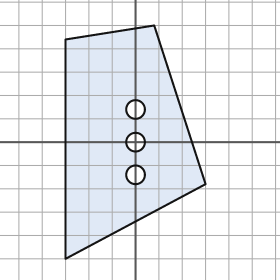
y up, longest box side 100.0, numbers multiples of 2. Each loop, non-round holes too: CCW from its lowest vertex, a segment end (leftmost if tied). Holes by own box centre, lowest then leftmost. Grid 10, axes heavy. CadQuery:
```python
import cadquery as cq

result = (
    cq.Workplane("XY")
    .moveTo(-30.0, -50.0)
    .lineTo(30.0, -18.0)
    .lineTo(8.0, 50.0)
    .lineTo(-30.0, 44.0)
    .close()
    .moveTo(0.0, -14.0)
    .circle(4.0)
    .moveTo(0.0, 0.0)
    .circle(4.0)
    .moveTo(0.0, 14.0)
    .circle(4.0)
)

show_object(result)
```